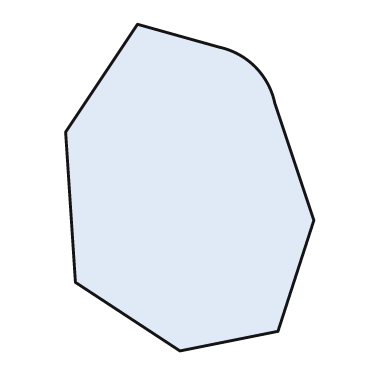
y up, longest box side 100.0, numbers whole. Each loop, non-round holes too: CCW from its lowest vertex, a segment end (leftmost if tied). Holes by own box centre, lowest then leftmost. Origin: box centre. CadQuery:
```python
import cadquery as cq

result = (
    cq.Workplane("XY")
    .moveTo(-3.0, -50.0)
    .lineTo(27.0, -44.0)
    .lineTo(38.0, -10.0)
    .lineTo(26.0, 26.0)
    .threePointArc((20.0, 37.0), (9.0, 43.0))
    .lineTo(-16.0, 50.0)
    .lineTo(-38.0, 17.0)
    .lineTo(-35.0, -29.0)
    .close()
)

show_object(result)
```